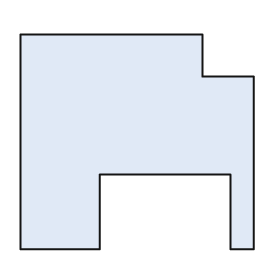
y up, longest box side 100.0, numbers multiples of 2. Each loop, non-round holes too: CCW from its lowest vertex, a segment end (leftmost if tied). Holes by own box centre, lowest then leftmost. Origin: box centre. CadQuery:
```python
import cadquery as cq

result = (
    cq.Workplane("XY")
    .moveTo(-50.0, -46.0)
    .lineTo(-16.0, -46.0)
    .lineTo(-16.0, -14.0)
    .lineTo(40.0, -14.0)
    .lineTo(40.0, -46.0)
    .lineTo(50.0, -46.0)
    .lineTo(50.0, 28.0)
    .lineTo(28.0, 28.0)
    .lineTo(28.0, 46.0)
    .lineTo(-50.0, 46.0)
    .close()
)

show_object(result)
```